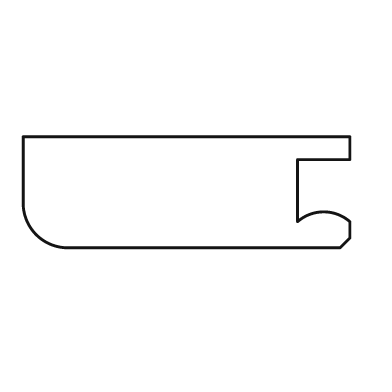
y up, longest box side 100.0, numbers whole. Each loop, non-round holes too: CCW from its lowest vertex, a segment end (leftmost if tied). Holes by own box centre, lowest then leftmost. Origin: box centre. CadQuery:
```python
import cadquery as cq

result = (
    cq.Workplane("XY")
    .moveTo(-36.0, -17.0)
    .lineTo(47.0, -17.0)
    .lineTo(50.0, -14.0)
    .lineTo(50.0, -9.0)
    .threePointArc((42.0, -6.0), (34.0, -9.0))
    .lineTo(34.0, 10.0)
    .lineTo(50.0, 10.0)
    .lineTo(50.0, 17.0)
    .lineTo(-50.0, 17.0)
    .lineTo(-50.0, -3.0)
    .threePointArc((-46.0, -13.0), (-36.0, -17.0))
    .close()
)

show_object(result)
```